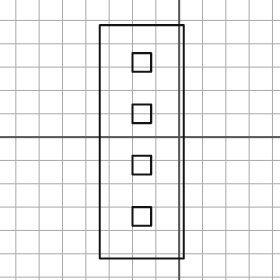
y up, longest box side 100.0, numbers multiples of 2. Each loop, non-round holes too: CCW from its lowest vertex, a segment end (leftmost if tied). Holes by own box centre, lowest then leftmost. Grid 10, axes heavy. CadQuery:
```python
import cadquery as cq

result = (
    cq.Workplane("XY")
    .moveTo(-34.0, -52.0)
    .lineTo(2.0, -52.0)
    .lineTo(2.0, 48.0)
    .lineTo(-34.0, 48.0)
    .close()
    .moveTo(-20.0, -38.0)
    .lineTo(-12.0, -38.0)
    .lineTo(-12.0, -30.0)
    .lineTo(-20.0, -30.0)
    .close()
    .moveTo(-20.0, -16.0)
    .lineTo(-12.0, -16.0)
    .lineTo(-12.0, -8.0)
    .lineTo(-20.0, -8.0)
    .close()
    .moveTo(-20.0, 6.0)
    .lineTo(-12.0, 6.0)
    .lineTo(-12.0, 14.0)
    .lineTo(-20.0, 14.0)
    .close()
    .moveTo(-20.0, 28.0)
    .lineTo(-12.0, 28.0)
    .lineTo(-12.0, 36.0)
    .lineTo(-20.0, 36.0)
    .close()
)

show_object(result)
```